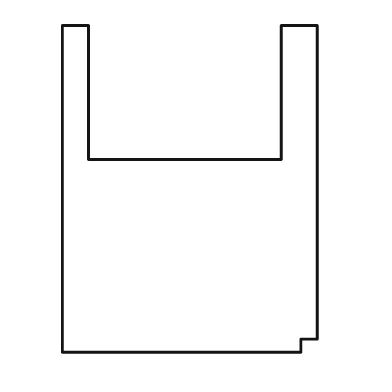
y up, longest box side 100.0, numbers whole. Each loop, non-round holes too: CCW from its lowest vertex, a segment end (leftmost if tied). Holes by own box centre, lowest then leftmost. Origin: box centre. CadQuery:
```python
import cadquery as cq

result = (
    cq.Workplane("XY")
    .moveTo(-39.0, -50.0)
    .lineTo(34.0, -50.0)
    .lineTo(34.0, -46.0)
    .lineTo(39.0, -46.0)
    .lineTo(39.0, 50.0)
    .lineTo(28.0, 50.0)
    .lineTo(28.0, 9.0)
    .lineTo(-31.0, 9.0)
    .lineTo(-31.0, 50.0)
    .lineTo(-39.0, 50.0)
    .close()
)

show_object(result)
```